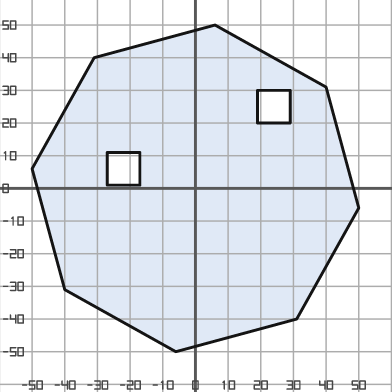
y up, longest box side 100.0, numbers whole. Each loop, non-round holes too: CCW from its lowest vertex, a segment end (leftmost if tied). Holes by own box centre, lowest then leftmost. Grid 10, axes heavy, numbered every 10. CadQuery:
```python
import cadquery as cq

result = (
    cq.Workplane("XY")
    .moveTo(-6.0, -50.0)
    .lineTo(31.0, -40.0)
    .lineTo(50.0, -6.0)
    .lineTo(40.0, 31.0)
    .lineTo(6.0, 50.0)
    .lineTo(-31.0, 40.0)
    .lineTo(-50.0, 6.0)
    .lineTo(-40.0, -31.0)
    .close()
    .moveTo(-27.0, 1.0)
    .lineTo(-17.0, 1.0)
    .lineTo(-17.0, 11.0)
    .lineTo(-27.0, 11.0)
    .close()
    .moveTo(19.0, 20.0)
    .lineTo(29.0, 20.0)
    .lineTo(29.0, 30.0)
    .lineTo(19.0, 30.0)
    .close()
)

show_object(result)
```